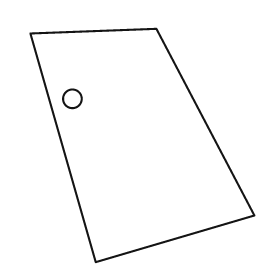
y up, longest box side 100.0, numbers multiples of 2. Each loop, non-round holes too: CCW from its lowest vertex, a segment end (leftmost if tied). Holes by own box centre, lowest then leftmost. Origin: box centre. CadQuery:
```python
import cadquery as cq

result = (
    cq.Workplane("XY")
    .moveTo(-20.0, -50.0)
    .lineTo(48.0, -30.0)
    .lineTo(6.0, 50.0)
    .lineTo(-48.0, 48.0)
    .close()
    .moveTo(-30.0, 20.0)
    .circle(4.0)
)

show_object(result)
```